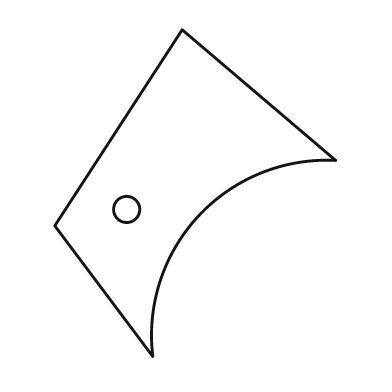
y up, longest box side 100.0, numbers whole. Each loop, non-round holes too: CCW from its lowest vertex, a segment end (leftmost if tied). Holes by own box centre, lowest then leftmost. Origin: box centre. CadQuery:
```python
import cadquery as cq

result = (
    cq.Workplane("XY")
    .moveTo(-13.0, -50.0)
    .threePointArc((1.0, -7.0), (43.0, 10.0))
    .lineTo(-4.0, 50.0)
    .lineTo(-43.0, -10.0)
    .close()
    .moveTo(-21.0, -5.0)
    .circle(4.0)
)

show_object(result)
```